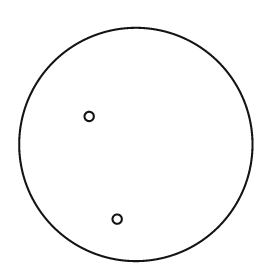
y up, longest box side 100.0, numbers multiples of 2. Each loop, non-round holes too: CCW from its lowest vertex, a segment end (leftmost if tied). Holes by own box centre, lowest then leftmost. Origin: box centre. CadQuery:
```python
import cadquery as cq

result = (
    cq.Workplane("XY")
    .moveTo(0.0, 0.0)
    .circle(50.0)
    .moveTo(-8.0, -32.0)
    .circle(2.0)
    .moveTo(-20.0, 12.0)
    .circle(2.0)
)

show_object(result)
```